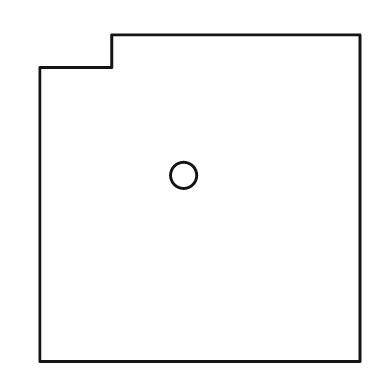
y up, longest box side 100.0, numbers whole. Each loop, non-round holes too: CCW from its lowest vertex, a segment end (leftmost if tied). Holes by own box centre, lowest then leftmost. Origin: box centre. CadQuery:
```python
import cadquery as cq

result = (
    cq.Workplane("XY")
    .moveTo(-49.0, -50.0)
    .lineTo(49.0, -50.0)
    .lineTo(49.0, 50.0)
    .lineTo(-27.0, 50.0)
    .lineTo(-27.0, 40.0)
    .lineTo(-49.0, 40.0)
    .close()
    .moveTo(-5.0, 7.0)
    .circle(4.0)
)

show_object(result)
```